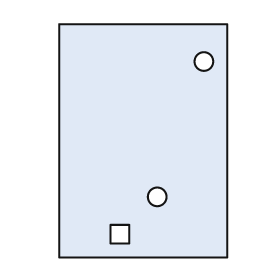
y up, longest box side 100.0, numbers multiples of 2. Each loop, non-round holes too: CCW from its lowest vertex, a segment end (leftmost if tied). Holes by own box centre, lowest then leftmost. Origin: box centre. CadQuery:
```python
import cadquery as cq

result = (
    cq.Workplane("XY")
    .moveTo(-36.0, -50.0)
    .lineTo(36.0, -50.0)
    .lineTo(36.0, 50.0)
    .lineTo(-36.0, 50.0)
    .close()
    .moveTo(-14.0, -44.0)
    .lineTo(-6.0, -44.0)
    .lineTo(-6.0, -36.0)
    .lineTo(-14.0, -36.0)
    .close()
    .moveTo(6.0, -24.0)
    .circle(4.0)
    .moveTo(26.0, 34.0)
    .circle(4.0)
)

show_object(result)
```